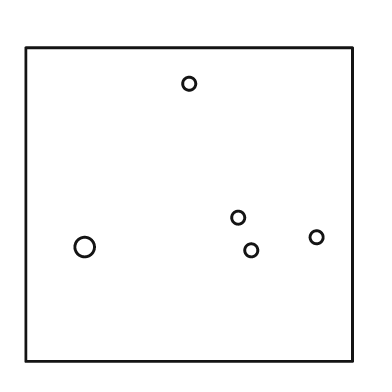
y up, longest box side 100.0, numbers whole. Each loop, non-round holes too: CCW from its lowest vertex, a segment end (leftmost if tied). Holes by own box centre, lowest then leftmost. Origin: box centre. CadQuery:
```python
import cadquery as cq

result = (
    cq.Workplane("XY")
    .moveTo(-50.0, -48.0)
    .lineTo(50.0, -48.0)
    .lineTo(50.0, 48.0)
    .lineTo(-50.0, 48.0)
    .close()
    .moveTo(19.0, -14.0)
    .circle(2.0)
    .moveTo(-32.0, -13.0)
    .circle(3.0)
    .moveTo(39.0, -10.0)
    .circle(2.0)
    .moveTo(15.0, -4.0)
    .circle(2.0)
    .moveTo(0.0, 37.0)
    .circle(2.0)
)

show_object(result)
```